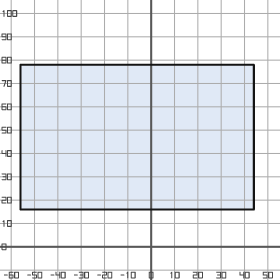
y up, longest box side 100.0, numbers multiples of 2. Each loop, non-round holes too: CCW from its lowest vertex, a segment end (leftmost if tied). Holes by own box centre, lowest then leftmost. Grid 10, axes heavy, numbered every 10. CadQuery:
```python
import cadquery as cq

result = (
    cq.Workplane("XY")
    .moveTo(-56.0, 16.0)
    .lineTo(44.0, 16.0)
    .lineTo(44.0, 78.0)
    .lineTo(-56.0, 78.0)
    .close()
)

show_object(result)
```